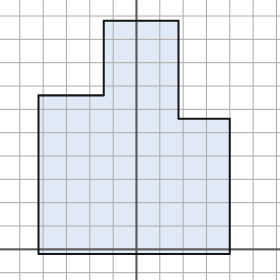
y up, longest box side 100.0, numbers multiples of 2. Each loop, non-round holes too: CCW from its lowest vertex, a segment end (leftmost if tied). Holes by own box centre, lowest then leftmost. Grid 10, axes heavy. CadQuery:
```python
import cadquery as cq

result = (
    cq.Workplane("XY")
    .moveTo(-42.0, -2.0)
    .lineTo(40.0, -2.0)
    .lineTo(40.0, 56.0)
    .lineTo(18.0, 56.0)
    .lineTo(18.0, 98.0)
    .lineTo(-14.0, 98.0)
    .lineTo(-14.0, 66.0)
    .lineTo(-42.0, 66.0)
    .close()
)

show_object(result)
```